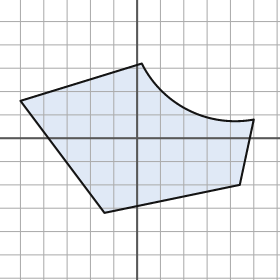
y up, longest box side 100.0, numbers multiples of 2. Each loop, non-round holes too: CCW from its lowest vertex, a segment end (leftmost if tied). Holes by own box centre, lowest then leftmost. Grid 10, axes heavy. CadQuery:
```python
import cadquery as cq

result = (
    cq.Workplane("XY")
    .moveTo(-14.0, -32.0)
    .lineTo(44.0, -20.0)
    .lineTo(50.0, 8.0)
    .threePointArc((22.0, 12.0), (2.0, 32.0))
    .lineTo(-50.0, 16.0)
    .close()
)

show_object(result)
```